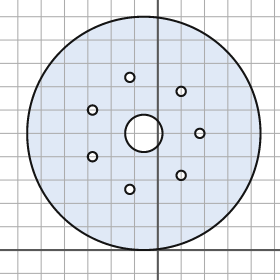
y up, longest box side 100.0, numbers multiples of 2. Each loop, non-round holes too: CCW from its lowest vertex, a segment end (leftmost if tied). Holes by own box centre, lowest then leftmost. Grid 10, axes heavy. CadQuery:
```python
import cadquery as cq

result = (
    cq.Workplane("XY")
    .moveTo(-6.0, 50.0)
    .circle(50.0)
    .moveTo(-12.0, 26.0)
    .circle(2.0)
    .moveTo(10.0, 32.0)
    .circle(2.0)
    .moveTo(-28.0, 40.0)
    .circle(2.0)
    .moveTo(-6.0, 50.0)
    .circle(8.0)
    .moveTo(18.0, 50.0)
    .circle(2.0)
    .moveTo(-28.0, 60.0)
    .circle(2.0)
    .moveTo(10.0, 68.0)
    .circle(2.0)
    .moveTo(-12.0, 74.0)
    .circle(2.0)
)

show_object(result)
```